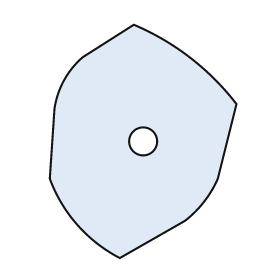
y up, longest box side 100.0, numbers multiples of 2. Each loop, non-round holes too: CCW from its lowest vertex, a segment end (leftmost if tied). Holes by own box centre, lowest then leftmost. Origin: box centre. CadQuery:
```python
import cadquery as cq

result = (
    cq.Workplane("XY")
    .moveTo(-10.0, -50.0)
    .lineTo(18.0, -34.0)
    .threePointArc((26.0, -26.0), (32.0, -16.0))
    .lineTo(40.0, 16.0)
    .threePointArc((20.0, 36.0), (-4.0, 50.0))
    .lineTo(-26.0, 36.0)
    .threePointArc((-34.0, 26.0), (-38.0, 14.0))
    .lineTo(-40.0, -16.0)
    .threePointArc((-28.0, -36.0), (-10.0, -50.0))
    .close()
    .moveTo(0.0, 0.0)
    .circle(6.0)
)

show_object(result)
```